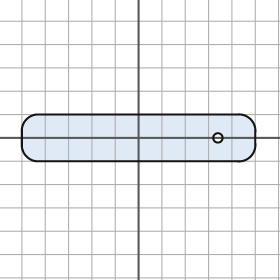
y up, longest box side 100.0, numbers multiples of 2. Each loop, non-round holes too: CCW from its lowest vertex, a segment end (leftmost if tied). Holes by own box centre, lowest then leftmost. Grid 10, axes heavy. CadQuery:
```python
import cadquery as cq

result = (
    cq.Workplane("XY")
    .moveTo(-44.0, -10.0)
    .lineTo(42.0, -10.0)
    .threePointArc((48.0, -8.0), (50.0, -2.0))
    .lineTo(50.0, 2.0)
    .threePointArc((48.0, 8.0), (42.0, 10.0))
    .lineTo(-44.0, 10.0)
    .threePointArc((-48.0, 8.0), (-50.0, 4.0))
    .lineTo(-50.0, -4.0)
    .threePointArc((-48.0, -8.0), (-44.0, -10.0))
    .close()
    .moveTo(34.0, 0.0)
    .circle(2.0)
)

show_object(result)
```